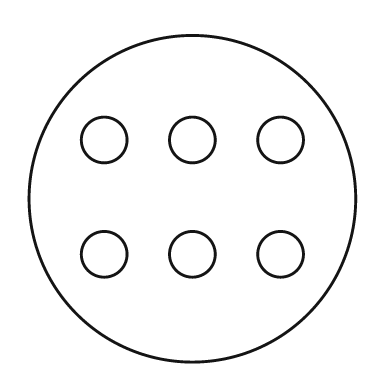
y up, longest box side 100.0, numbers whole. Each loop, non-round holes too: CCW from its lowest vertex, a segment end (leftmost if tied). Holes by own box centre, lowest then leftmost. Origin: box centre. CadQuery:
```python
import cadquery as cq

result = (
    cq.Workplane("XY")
    .moveTo(0.0, 0.0)
    .circle(50.0)
    .moveTo(-27.0, -17.0)
    .circle(7.0)
    .moveTo(0.0, -17.0)
    .circle(7.0)
    .moveTo(27.0, -17.0)
    .circle(7.0)
    .moveTo(-27.0, 18.0)
    .circle(7.0)
    .moveTo(0.0, 18.0)
    .circle(7.0)
    .moveTo(27.0, 18.0)
    .circle(7.0)
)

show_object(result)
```